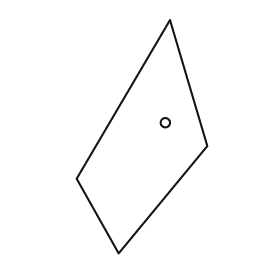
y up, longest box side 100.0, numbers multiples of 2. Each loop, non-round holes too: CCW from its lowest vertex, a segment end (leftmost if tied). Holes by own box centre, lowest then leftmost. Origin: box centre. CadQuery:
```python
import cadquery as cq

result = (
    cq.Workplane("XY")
    .moveTo(-10.0, -50.0)
    .lineTo(28.0, -4.0)
    .lineTo(12.0, 50.0)
    .lineTo(-28.0, -18.0)
    .close()
    .moveTo(10.0, 6.0)
    .circle(2.0)
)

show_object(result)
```